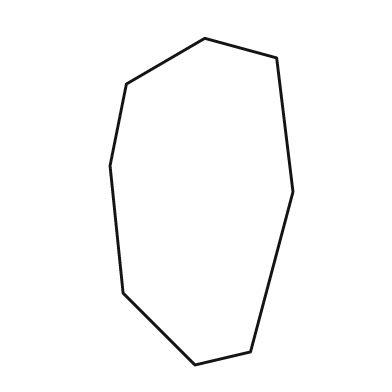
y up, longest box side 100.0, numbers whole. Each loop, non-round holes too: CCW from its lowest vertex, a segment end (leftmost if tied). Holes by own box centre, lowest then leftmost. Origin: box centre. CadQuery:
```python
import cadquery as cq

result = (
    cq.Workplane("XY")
    .moveTo(-2.0, -50.0)
    .lineTo(15.0, -46.0)
    .lineTo(28.0, 3.0)
    .lineTo(23.0, 44.0)
    .lineTo(1.0, 50.0)
    .lineTo(-23.0, 36.0)
    .lineTo(-28.0, 11.0)
    .lineTo(-24.0, -28.0)
    .close()
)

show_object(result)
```